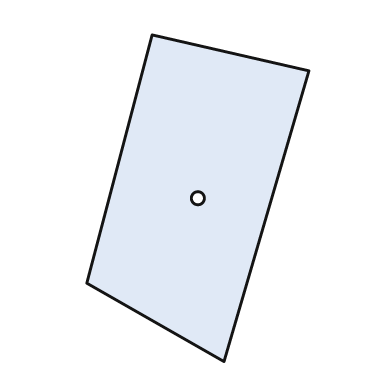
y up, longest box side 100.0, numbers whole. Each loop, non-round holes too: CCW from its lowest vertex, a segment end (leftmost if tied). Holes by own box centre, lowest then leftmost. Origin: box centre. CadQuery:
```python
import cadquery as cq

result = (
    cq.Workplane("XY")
    .moveTo(8.0, -50.0)
    .lineTo(34.0, 39.0)
    .lineTo(-14.0, 50.0)
    .lineTo(-34.0, -26.0)
    .close()
    .moveTo(0.0, 0.0)
    .circle(2.0)
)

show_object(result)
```